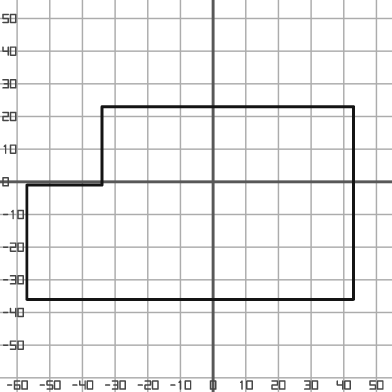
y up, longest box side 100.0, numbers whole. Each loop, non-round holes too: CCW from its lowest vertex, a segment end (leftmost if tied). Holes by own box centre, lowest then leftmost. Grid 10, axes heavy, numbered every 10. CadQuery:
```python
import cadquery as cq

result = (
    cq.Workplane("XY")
    .moveTo(-57.0, -36.0)
    .lineTo(43.0, -36.0)
    .lineTo(43.0, 23.0)
    .lineTo(-34.0, 23.0)
    .lineTo(-34.0, -1.0)
    .lineTo(-57.0, -1.0)
    .close()
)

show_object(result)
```